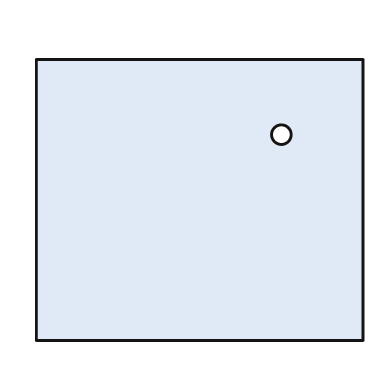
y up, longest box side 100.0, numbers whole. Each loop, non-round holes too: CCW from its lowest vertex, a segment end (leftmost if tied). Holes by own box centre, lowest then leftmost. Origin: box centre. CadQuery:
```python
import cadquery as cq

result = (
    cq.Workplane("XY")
    .moveTo(-50.0, -43.0)
    .lineTo(50.0, -43.0)
    .lineTo(50.0, 43.0)
    .lineTo(-50.0, 43.0)
    .close()
    .moveTo(25.0, 20.0)
    .circle(3.0)
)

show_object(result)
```